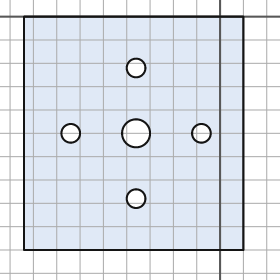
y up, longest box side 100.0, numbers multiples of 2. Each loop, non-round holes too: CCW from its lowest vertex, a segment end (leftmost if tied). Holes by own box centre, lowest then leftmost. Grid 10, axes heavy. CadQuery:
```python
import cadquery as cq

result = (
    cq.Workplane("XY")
    .moveTo(-84.0, -100.0)
    .lineTo(10.0, -100.0)
    .lineTo(10.0, 0.0)
    .lineTo(-84.0, 0.0)
    .close()
    .moveTo(-36.0, -78.0)
    .circle(4.0)
    .moveTo(-64.0, -50.0)
    .circle(4.0)
    .moveTo(-36.0, -50.0)
    .circle(6.0)
    .moveTo(-8.0, -50.0)
    .circle(4.0)
    .moveTo(-36.0, -22.0)
    .circle(4.0)
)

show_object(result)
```